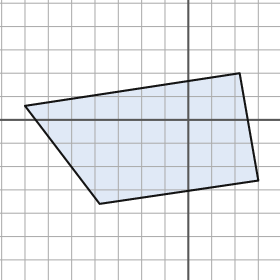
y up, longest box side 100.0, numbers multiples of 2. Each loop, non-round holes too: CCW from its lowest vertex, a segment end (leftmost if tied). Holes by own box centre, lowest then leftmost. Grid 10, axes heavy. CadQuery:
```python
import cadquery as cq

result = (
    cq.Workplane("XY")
    .moveTo(-38.0, -36.0)
    .lineTo(30.0, -26.0)
    .lineTo(22.0, 20.0)
    .lineTo(-70.0, 6.0)
    .close()
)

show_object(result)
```